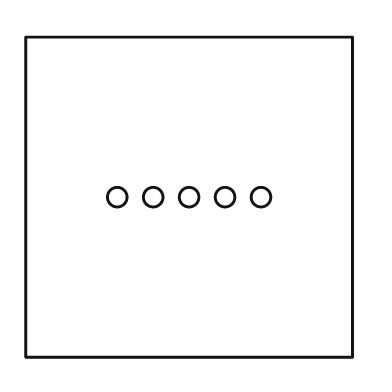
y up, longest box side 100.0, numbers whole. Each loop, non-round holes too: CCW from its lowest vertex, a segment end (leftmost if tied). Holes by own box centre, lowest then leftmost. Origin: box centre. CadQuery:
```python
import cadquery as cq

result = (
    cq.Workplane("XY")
    .moveTo(-50.0, -49.0)
    .lineTo(50.0, -49.0)
    .lineTo(50.0, 49.0)
    .lineTo(-50.0, 49.0)
    .close()
    .moveTo(-22.0, 0.0)
    .circle(3.0)
    .moveTo(-11.0, 0.0)
    .circle(3.0)
    .moveTo(0.0, 0.0)
    .circle(3.0)
    .moveTo(11.0, 0.0)
    .circle(3.0)
    .moveTo(22.0, 0.0)
    .circle(3.0)
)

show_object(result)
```